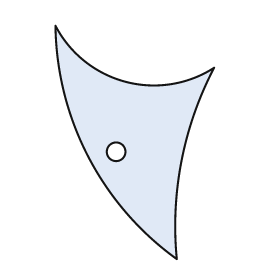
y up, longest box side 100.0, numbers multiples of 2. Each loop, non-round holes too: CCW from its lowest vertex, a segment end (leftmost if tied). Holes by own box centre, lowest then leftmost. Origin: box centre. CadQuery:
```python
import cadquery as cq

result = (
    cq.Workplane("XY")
    .moveTo(18.0, -50.0)
    .threePointArc((20.0, -8.0), (34.0, 32.0))
    .threePointArc((-4.0, 26.0), (-34.0, 50.0))
    .threePointArc((-20.0, -6.0), (18.0, -50.0))
    .close()
    .moveTo(-8.0, -4.0)
    .circle(4.0)
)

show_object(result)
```